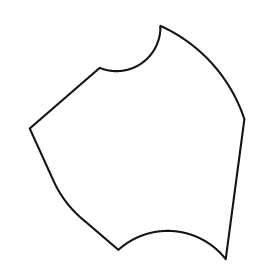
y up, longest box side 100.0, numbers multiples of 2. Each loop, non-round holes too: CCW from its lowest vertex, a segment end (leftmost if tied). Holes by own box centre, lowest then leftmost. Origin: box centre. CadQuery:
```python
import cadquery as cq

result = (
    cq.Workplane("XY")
    .moveTo(38.0, -50.0)
    .lineTo(46.0, 10.0)
    .threePointArc((32.0, 34.0), (10.0, 50.0))
    .threePointArc((2.0, 34.0), (-16.0, 32.0))
    .lineTo(-46.0, 6.0)
    .lineTo(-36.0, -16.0)
    .threePointArc((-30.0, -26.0), (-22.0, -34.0))
    .lineTo(-8.0, -46.0)
    .threePointArc((16.0, -38.0), (38.0, -50.0))
    .close()
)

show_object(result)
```